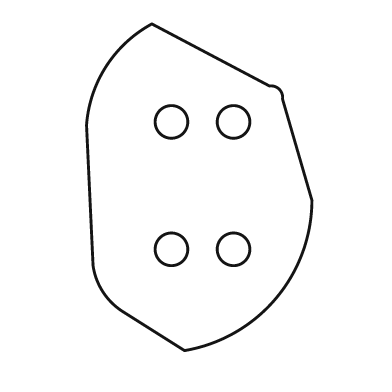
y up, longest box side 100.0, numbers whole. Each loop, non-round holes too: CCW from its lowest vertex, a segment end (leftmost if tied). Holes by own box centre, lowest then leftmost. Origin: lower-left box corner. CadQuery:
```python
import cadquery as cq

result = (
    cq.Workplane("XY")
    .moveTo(30.0, 0.0)
    .threePointArc((58.0, 16.0), (69.0, 46.0))
    .lineTo(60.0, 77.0)
    .threePointArc((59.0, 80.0), (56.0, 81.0))
    .lineTo(20.0, 100.0)
    .threePointArc((6.0, 87.0), (0.0, 69.0))
    .lineTo(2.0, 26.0)
    .threePointArc((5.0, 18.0), (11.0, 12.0))
    .close()
    .moveTo(26.0, 31.0)
    .circle(5.0)
    .moveTo(45.0, 31.0)
    .circle(5.0)
    .moveTo(26.0, 70.0)
    .circle(5.0)
    .moveTo(45.0, 70.0)
    .circle(5.0)
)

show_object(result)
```